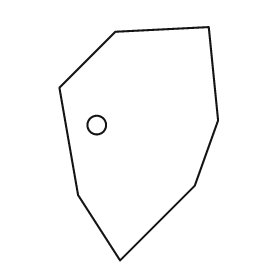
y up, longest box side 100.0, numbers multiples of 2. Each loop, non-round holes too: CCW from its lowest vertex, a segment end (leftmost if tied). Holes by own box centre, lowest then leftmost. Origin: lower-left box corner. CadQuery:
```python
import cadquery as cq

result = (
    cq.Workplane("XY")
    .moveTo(26.0, 0.0)
    .lineTo(58.0, 32.0)
    .lineTo(68.0, 60.0)
    .lineTo(64.0, 100.0)
    .lineTo(24.0, 98.0)
    .lineTo(0.0, 74.0)
    .lineTo(8.0, 28.0)
    .close()
    .moveTo(16.0, 58.0)
    .circle(4.0)
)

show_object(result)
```